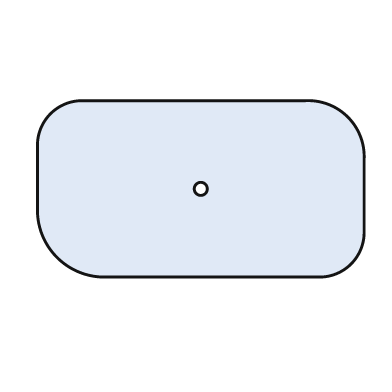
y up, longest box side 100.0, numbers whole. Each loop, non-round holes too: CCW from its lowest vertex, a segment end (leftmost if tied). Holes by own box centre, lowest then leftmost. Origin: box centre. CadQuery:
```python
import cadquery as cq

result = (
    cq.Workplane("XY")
    .moveTo(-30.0, -27.0)
    .lineTo(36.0, -27.0)
    .threePointArc((46.0, -23.0), (50.0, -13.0))
    .lineTo(50.0, 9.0)
    .threePointArc((45.0, 22.0), (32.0, 27.0))
    .lineTo(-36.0, 27.0)
    .threePointArc((-46.0, 23.0), (-50.0, 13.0))
    .lineTo(-50.0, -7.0)
    .threePointArc((-44.0, -21.0), (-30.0, -27.0))
    .close()
    .moveTo(0.0, 0.0)
    .circle(2.0)
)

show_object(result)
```